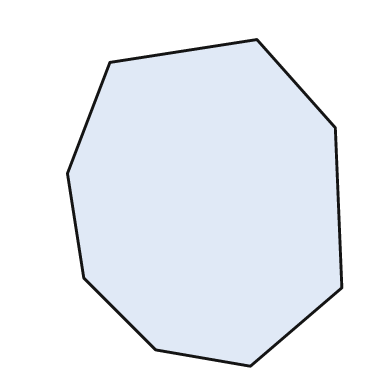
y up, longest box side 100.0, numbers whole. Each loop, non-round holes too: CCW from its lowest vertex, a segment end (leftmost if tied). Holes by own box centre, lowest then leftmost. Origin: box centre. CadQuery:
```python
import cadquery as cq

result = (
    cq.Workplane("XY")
    .moveTo(14.0, -50.0)
    .lineTo(42.0, -26.0)
    .lineTo(40.0, 23.0)
    .lineTo(16.0, 50.0)
    .lineTo(-29.0, 43.0)
    .lineTo(-42.0, 9.0)
    .lineTo(-37.0, -23.0)
    .lineTo(-15.0, -45.0)
    .close()
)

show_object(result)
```